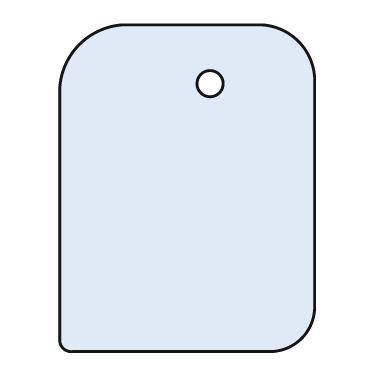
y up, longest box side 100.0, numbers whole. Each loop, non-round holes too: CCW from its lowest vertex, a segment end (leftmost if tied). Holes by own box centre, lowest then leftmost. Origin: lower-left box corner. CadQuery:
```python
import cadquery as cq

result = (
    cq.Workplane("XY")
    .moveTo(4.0, 0.0)
    .lineTo(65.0, 0.0)
    .threePointArc((74.0, 4.0), (78.0, 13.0))
    .lineTo(78.0, 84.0)
    .threePointArc((73.0, 95.0), (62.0, 100.0))
    .lineTo(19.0, 100.0)
    .threePointArc((6.0, 94.0), (0.0, 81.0))
    .lineTo(0.0, 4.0)
    .threePointArc((1.0, 1.0), (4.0, 0.0))
    .close()
    .moveTo(46.0, 82.0)
    .circle(4.0)
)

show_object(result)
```